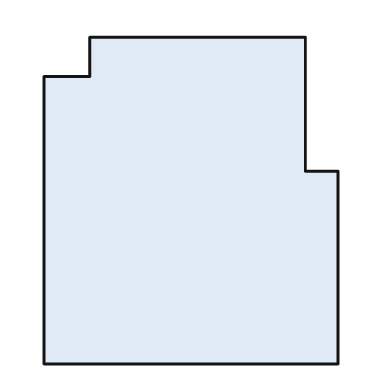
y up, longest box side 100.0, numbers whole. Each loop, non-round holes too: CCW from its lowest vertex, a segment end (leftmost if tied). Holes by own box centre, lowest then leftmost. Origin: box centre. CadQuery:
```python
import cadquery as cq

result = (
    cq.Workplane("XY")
    .moveTo(-45.0, -50.0)
    .lineTo(45.0, -50.0)
    .lineTo(45.0, 9.0)
    .lineTo(35.0, 9.0)
    .lineTo(35.0, 50.0)
    .lineTo(-31.0, 50.0)
    .lineTo(-31.0, 38.0)
    .lineTo(-45.0, 38.0)
    .close()
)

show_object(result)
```